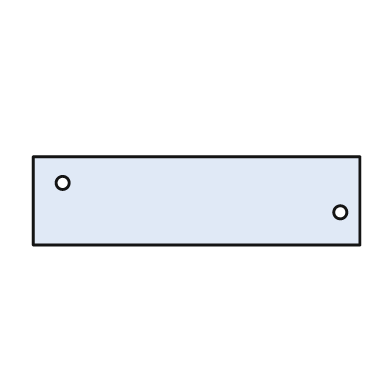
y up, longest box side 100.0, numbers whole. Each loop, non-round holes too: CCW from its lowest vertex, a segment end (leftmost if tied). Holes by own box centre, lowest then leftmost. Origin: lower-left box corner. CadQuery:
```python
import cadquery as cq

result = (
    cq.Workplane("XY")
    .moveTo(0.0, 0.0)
    .lineTo(100.0, 0.0)
    .lineTo(100.0, 27.0)
    .lineTo(0.0, 27.0)
    .close()
    .moveTo(94.0, 10.0)
    .circle(2.0)
    .moveTo(9.0, 19.0)
    .circle(2.0)
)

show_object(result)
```